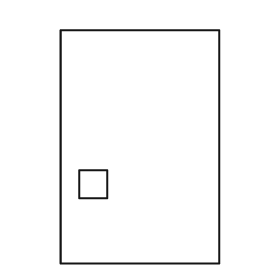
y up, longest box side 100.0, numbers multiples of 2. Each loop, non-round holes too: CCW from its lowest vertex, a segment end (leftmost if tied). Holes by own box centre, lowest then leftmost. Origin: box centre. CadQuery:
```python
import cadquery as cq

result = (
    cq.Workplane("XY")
    .moveTo(-34.0, -50.0)
    .lineTo(34.0, -50.0)
    .lineTo(34.0, 50.0)
    .lineTo(-34.0, 50.0)
    .close()
    .moveTo(-26.0, -22.0)
    .lineTo(-14.0, -22.0)
    .lineTo(-14.0, -10.0)
    .lineTo(-26.0, -10.0)
    .close()
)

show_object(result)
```